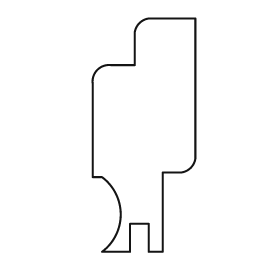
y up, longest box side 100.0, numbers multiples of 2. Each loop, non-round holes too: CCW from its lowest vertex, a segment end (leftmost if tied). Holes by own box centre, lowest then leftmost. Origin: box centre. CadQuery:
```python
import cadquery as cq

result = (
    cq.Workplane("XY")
    .moveTo(-18.0, -50.0)
    .lineTo(-6.0, -50.0)
    .lineTo(-6.0, -38.0)
    .lineTo(2.0, -38.0)
    .lineTo(2.0, -50.0)
    .lineTo(8.0, -50.0)
    .lineTo(8.0, -16.0)
    .lineTo(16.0, -16.0)
    .threePointArc((20.0, -14.0), (22.0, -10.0))
    .lineTo(22.0, 50.0)
    .lineTo(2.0, 50.0)
    .threePointArc((-2.0, 48.0), (-4.0, 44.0))
    .lineTo(-4.0, 30.0)
    .lineTo(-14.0, 30.0)
    .threePointArc((-20.0, 28.0), (-22.0, 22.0))
    .lineTo(-22.0, -18.0)
    .lineTo(-18.0, -18.0)
    .threePointArc((-10.0, -34.0), (-18.0, -50.0))
    .close()
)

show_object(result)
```